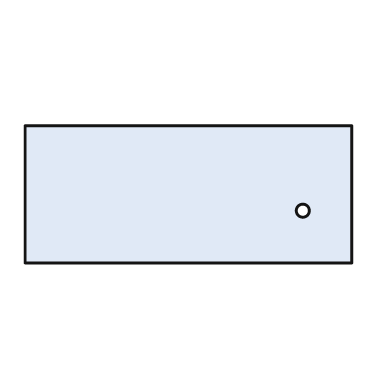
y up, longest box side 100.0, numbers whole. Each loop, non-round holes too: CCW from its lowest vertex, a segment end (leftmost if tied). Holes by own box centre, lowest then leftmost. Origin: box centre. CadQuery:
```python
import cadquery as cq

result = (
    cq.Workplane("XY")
    .moveTo(-50.0, -21.0)
    .lineTo(50.0, -21.0)
    .lineTo(50.0, 21.0)
    .lineTo(-50.0, 21.0)
    .close()
    .moveTo(35.0, -5.0)
    .circle(2.0)
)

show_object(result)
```